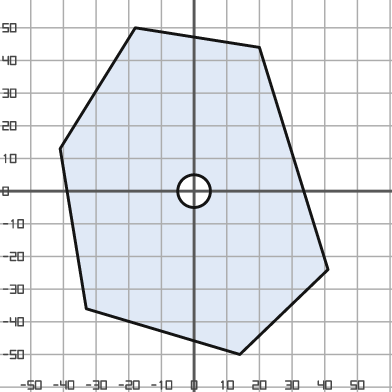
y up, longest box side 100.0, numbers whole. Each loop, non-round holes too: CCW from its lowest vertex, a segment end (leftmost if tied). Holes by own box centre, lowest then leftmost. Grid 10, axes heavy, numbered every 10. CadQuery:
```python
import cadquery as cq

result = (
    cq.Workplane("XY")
    .moveTo(14.0, -50.0)
    .lineTo(41.0, -24.0)
    .lineTo(20.0, 44.0)
    .lineTo(-18.0, 50.0)
    .lineTo(-41.0, 13.0)
    .lineTo(-33.0, -36.0)
    .close()
    .moveTo(0.0, 0.0)
    .circle(5.0)
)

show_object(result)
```